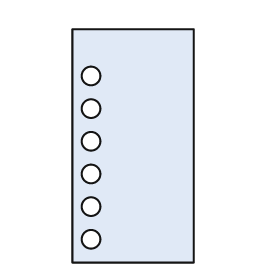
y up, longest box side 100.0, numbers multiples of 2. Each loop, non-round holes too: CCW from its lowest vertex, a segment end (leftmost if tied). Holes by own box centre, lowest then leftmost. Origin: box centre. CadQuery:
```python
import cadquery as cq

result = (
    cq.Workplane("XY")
    .moveTo(-26.0, -50.0)
    .lineTo(26.0, -50.0)
    .lineTo(26.0, 50.0)
    .lineTo(-26.0, 50.0)
    .close()
    .moveTo(-18.0, -40.0)
    .circle(4.0)
    .moveTo(-18.0, -26.0)
    .circle(4.0)
    .moveTo(-18.0, -12.0)
    .circle(4.0)
    .moveTo(-18.0, 2.0)
    .circle(4.0)
    .moveTo(-18.0, 16.0)
    .circle(4.0)
    .moveTo(-18.0, 30.0)
    .circle(4.0)
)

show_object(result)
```